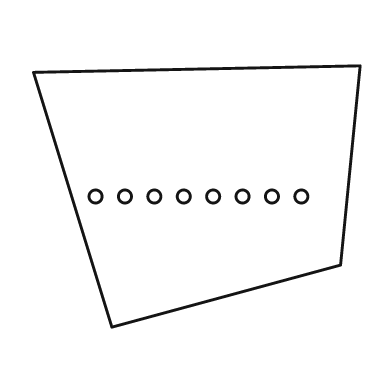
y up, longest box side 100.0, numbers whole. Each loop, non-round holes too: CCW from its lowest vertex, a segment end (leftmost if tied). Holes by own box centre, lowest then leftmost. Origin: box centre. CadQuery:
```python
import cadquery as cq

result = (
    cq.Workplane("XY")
    .moveTo(-26.0, -40.0)
    .lineTo(44.0, -21.0)
    .lineTo(50.0, 40.0)
    .lineTo(-50.0, 38.0)
    .close()
    .moveTo(-31.0, 0.0)
    .circle(2.0)
    .moveTo(-22.0, 0.0)
    .circle(2.0)
    .moveTo(-13.0, 0.0)
    .circle(2.0)
    .moveTo(-4.0, 0.0)
    .circle(2.0)
    .moveTo(5.0, 0.0)
    .circle(2.0)
    .moveTo(14.0, 0.0)
    .circle(2.0)
    .moveTo(23.0, 0.0)
    .circle(2.0)
    .moveTo(32.0, 0.0)
    .circle(2.0)
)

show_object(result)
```